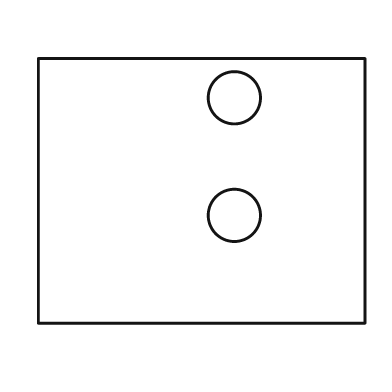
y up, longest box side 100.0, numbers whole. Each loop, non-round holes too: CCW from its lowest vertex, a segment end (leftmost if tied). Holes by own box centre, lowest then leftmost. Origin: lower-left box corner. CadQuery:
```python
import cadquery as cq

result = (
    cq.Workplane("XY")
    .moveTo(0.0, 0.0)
    .lineTo(100.0, 0.0)
    .lineTo(100.0, 81.0)
    .lineTo(0.0, 81.0)
    .close()
    .moveTo(60.0, 33.0)
    .circle(8.0)
    .moveTo(60.0, 69.0)
    .circle(8.0)
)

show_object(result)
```